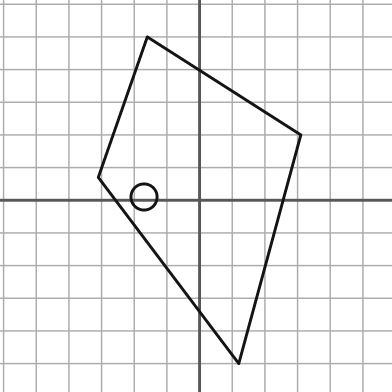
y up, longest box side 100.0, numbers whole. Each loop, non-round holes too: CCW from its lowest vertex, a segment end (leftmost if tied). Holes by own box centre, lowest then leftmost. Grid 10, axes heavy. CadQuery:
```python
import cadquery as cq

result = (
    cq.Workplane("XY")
    .moveTo(12.0, -50.0)
    .lineTo(31.0, 20.0)
    .lineTo(-16.0, 50.0)
    .lineTo(-31.0, 7.0)
    .close()
    .moveTo(-17.0, 1.0)
    .circle(4.0)
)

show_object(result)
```